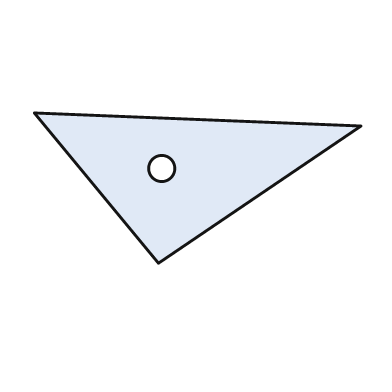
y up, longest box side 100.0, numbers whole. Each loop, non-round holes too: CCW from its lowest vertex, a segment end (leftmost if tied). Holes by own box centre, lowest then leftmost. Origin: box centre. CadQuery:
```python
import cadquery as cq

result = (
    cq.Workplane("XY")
    .moveTo(-12.0, -23.0)
    .lineTo(50.0, 19.0)
    .lineTo(-50.0, 23.0)
    .close()
    .moveTo(-11.0, 6.0)
    .circle(4.0)
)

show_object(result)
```